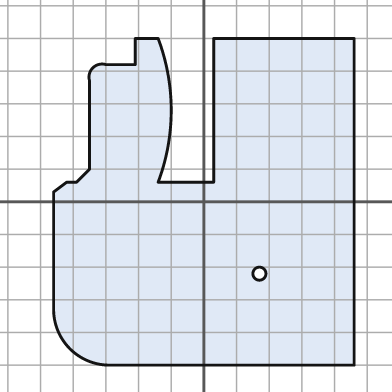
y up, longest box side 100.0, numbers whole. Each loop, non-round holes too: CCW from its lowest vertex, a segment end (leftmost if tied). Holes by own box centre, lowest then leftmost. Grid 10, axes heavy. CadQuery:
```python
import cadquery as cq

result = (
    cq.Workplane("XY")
    .moveTo(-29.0, -50.0)
    .lineTo(46.0, -50.0)
    .lineTo(46.0, 50.0)
    .lineTo(3.0, 50.0)
    .lineTo(3.0, 6.0)
    .lineTo(-14.0, 6.0)
    .threePointArc((-10.0, 28.0), (-14.0, 50.0))
    .lineTo(-21.0, 50.0)
    .lineTo(-21.0, 42.0)
    .lineTo(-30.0, 42.0)
    .threePointArc((-34.0, 41.0), (-35.0, 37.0))
    .lineTo(-35.0, 10.0)
    .lineTo(-39.0, 6.0)
    .lineTo(-42.0, 6.0)
    .lineTo(-46.0, 3.0)
    .lineTo(-46.0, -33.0)
    .threePointArc((-41.0, -45.0), (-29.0, -50.0))
    .close()
    .moveTo(17.0, -22.0)
    .circle(2.0)
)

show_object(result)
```